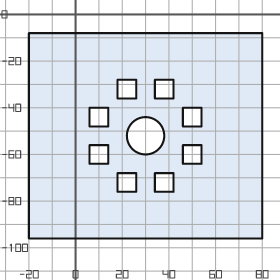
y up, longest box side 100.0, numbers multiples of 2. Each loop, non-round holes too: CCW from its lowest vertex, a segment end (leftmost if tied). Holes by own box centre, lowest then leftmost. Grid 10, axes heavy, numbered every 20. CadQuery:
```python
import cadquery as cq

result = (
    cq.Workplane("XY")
    .moveTo(-20.0, -96.0)
    .lineTo(80.0, -96.0)
    .lineTo(80.0, -8.0)
    .lineTo(-20.0, -8.0)
    .close()
    .moveTo(18.0, -76.0)
    .lineTo(26.0, -76.0)
    .lineTo(26.0, -68.0)
    .lineTo(18.0, -68.0)
    .close()
    .moveTo(34.0, -76.0)
    .lineTo(42.0, -76.0)
    .lineTo(42.0, -68.0)
    .lineTo(34.0, -68.0)
    .close()
    .moveTo(6.0, -64.0)
    .lineTo(14.0, -64.0)
    .lineTo(14.0, -56.0)
    .lineTo(6.0, -56.0)
    .close()
    .moveTo(46.0, -64.0)
    .lineTo(54.0, -64.0)
    .lineTo(54.0, -56.0)
    .lineTo(46.0, -56.0)
    .close()
    .moveTo(30.0, -52.0)
    .circle(8.0)
    .moveTo(6.0, -48.0)
    .lineTo(14.0, -48.0)
    .lineTo(14.0, -40.0)
    .lineTo(6.0, -40.0)
    .close()
    .moveTo(46.0, -48.0)
    .lineTo(54.0, -48.0)
    .lineTo(54.0, -40.0)
    .lineTo(46.0, -40.0)
    .close()
    .moveTo(18.0, -36.0)
    .lineTo(26.0, -36.0)
    .lineTo(26.0, -28.0)
    .lineTo(18.0, -28.0)
    .close()
    .moveTo(34.0, -36.0)
    .lineTo(42.0, -36.0)
    .lineTo(42.0, -28.0)
    .lineTo(34.0, -28.0)
    .close()
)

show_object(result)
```